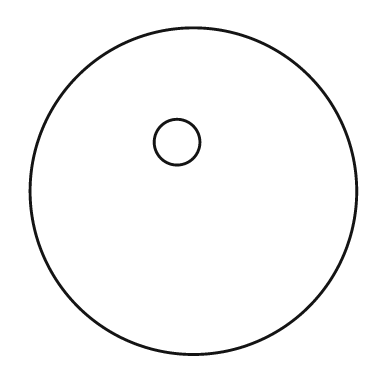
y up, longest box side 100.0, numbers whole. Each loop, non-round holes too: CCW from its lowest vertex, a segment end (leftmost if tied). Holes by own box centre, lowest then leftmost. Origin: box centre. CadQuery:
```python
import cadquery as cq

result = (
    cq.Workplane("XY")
    .moveTo(0.0, 0.0)
    .circle(50.0)
    .moveTo(-5.0, 15.0)
    .circle(7.0)
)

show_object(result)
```